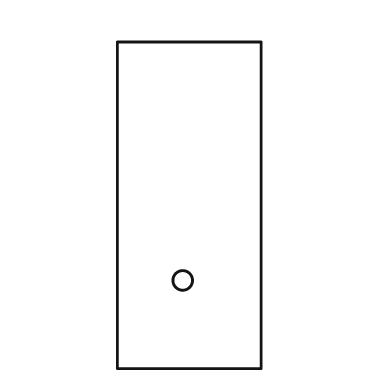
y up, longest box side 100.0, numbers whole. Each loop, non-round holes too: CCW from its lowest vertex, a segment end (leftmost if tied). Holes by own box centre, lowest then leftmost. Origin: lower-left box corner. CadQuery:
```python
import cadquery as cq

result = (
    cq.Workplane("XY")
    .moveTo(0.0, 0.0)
    .lineTo(44.0, 0.0)
    .lineTo(44.0, 100.0)
    .lineTo(0.0, 100.0)
    .close()
    .moveTo(20.0, 27.0)
    .circle(3.0)
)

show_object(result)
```